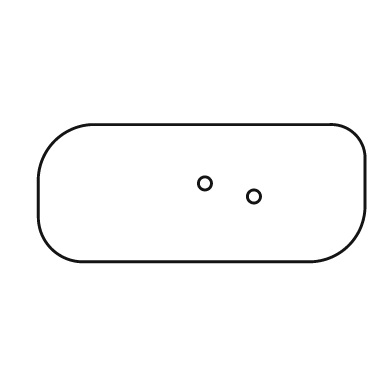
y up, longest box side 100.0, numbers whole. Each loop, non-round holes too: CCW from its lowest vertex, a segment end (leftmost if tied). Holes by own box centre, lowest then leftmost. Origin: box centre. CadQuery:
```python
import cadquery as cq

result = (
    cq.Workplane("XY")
    .moveTo(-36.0, -21.0)
    .lineTo(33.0, -21.0)
    .threePointArc((45.0, -16.0), (50.0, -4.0))
    .lineTo(50.0, 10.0)
    .threePointArc((47.0, 18.0), (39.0, 21.0))
    .lineTo(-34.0, 21.0)
    .threePointArc((-45.0, 16.0), (-50.0, 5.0))
    .lineTo(-50.0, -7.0)
    .threePointArc((-46.0, -17.0), (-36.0, -21.0))
    .close()
    .moveTo(16.0, -1.0)
    .circle(2.0)
    .moveTo(1.0, 3.0)
    .circle(2.0)
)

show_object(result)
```